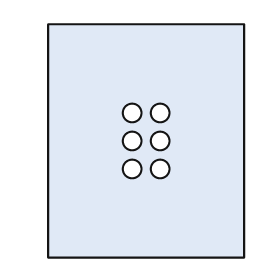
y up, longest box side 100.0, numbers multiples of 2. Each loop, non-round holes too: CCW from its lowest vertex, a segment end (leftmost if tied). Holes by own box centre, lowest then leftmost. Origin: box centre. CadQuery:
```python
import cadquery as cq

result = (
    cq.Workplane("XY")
    .moveTo(-42.0, -50.0)
    .lineTo(42.0, -50.0)
    .lineTo(42.0, 50.0)
    .lineTo(-42.0, 50.0)
    .close()
    .moveTo(-6.0, -12.0)
    .circle(4.0)
    .moveTo(6.0, -12.0)
    .circle(4.0)
    .moveTo(-6.0, 0.0)
    .circle(4.0)
    .moveTo(6.0, 0.0)
    .circle(4.0)
    .moveTo(-6.0, 12.0)
    .circle(4.0)
    .moveTo(6.0, 12.0)
    .circle(4.0)
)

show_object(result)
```